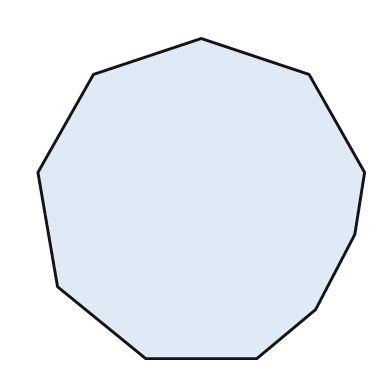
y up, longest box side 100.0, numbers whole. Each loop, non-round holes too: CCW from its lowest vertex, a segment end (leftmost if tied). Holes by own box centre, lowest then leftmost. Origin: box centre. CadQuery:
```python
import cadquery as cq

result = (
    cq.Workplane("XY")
    .moveTo(-17.0, -49.0)
    .lineTo(17.0, -49.0)
    .lineTo(35.0, -34.0)
    .lineTo(47.0, -11.0)
    .lineTo(50.0, 8.0)
    .lineTo(33.0, 38.0)
    .lineTo(0.0, 49.0)
    .lineTo(-33.0, 38.0)
    .lineTo(-50.0, 8.0)
    .lineTo(-44.0, -27.0)
    .close()
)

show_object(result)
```